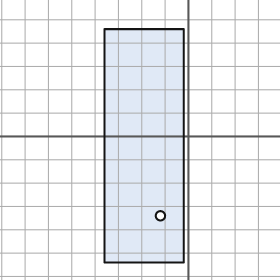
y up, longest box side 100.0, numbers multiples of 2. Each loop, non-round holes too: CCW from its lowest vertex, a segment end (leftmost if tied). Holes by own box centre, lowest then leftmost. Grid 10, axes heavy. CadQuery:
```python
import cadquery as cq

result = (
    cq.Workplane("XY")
    .moveTo(-36.0, -54.0)
    .lineTo(-2.0, -54.0)
    .lineTo(-2.0, 46.0)
    .lineTo(-36.0, 46.0)
    .close()
    .moveTo(-12.0, -34.0)
    .circle(2.0)
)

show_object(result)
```